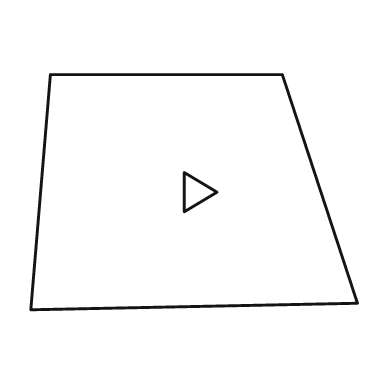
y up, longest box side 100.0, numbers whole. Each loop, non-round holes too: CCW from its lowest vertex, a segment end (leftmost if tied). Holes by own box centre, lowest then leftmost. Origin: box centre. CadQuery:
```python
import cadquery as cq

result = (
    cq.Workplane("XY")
    .moveTo(-50.0, -36.0)
    .lineTo(50.0, -34.0)
    .lineTo(27.0, 36.0)
    .lineTo(-44.0, 36.0)
    .close()
    .moveTo(-3.0, -6.0)
    .lineTo(7.0, 0.0)
    .lineTo(-3.0, 6.0)
    .close()
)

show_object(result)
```